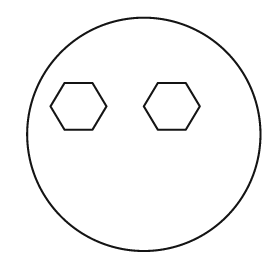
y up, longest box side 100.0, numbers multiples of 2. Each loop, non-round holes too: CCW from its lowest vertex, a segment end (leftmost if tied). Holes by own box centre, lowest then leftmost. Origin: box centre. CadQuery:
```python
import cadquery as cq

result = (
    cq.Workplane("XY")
    .moveTo(0.0, 0.0)
    .circle(50.0)
    .moveTo(-34.0, 2.0)
    .lineTo(-22.0, 2.0)
    .lineTo(-16.0, 12.0)
    .lineTo(-22.0, 22.0)
    .lineTo(-34.0, 22.0)
    .lineTo(-40.0, 12.0)
    .close()
    .moveTo(6.0, 2.0)
    .lineTo(18.0, 2.0)
    .lineTo(24.0, 12.0)
    .lineTo(18.0, 22.0)
    .lineTo(6.0, 22.0)
    .lineTo(0.0, 12.0)
    .close()
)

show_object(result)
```